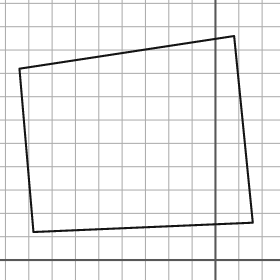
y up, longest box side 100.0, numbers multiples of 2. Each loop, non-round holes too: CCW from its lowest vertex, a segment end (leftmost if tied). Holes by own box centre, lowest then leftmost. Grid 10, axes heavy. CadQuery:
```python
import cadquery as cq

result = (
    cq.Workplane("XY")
    .moveTo(-78.0, 12.0)
    .lineTo(16.0, 16.0)
    .lineTo(8.0, 96.0)
    .lineTo(-84.0, 82.0)
    .close()
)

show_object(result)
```